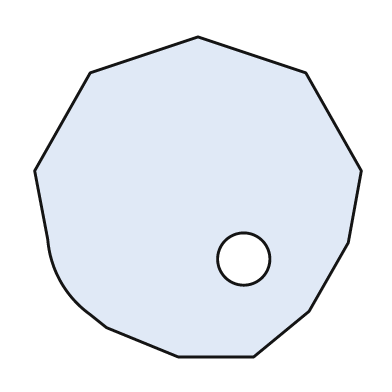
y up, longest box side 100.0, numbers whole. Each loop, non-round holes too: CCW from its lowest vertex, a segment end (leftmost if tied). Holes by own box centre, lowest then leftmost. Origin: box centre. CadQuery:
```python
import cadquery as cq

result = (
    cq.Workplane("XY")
    .moveTo(-6.0, -49.0)
    .lineTo(17.0, -49.0)
    .lineTo(34.0, -35.0)
    .lineTo(46.0, -14.0)
    .lineTo(50.0, 8.0)
    .lineTo(33.0, 38.0)
    .lineTo(0.0, 49.0)
    .lineTo(-33.0, 38.0)
    .lineTo(-50.0, 8.0)
    .lineTo(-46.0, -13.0)
    .threePointArc((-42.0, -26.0), (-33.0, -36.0))
    .lineTo(-28.0, -40.0)
    .close()
    .moveTo(14.0, -19.0)
    .circle(8.0)
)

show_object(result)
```